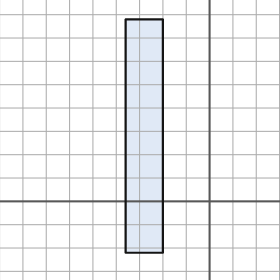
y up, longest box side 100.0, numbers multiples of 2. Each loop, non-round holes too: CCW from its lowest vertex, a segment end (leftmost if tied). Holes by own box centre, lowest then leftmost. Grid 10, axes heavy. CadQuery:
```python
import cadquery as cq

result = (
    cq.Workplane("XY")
    .moveTo(-36.0, -22.0)
    .lineTo(-20.0, -22.0)
    .lineTo(-20.0, 78.0)
    .lineTo(-36.0, 78.0)
    .close()
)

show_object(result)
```